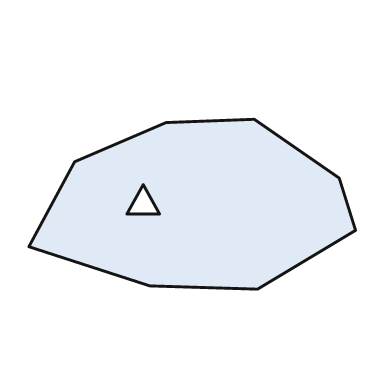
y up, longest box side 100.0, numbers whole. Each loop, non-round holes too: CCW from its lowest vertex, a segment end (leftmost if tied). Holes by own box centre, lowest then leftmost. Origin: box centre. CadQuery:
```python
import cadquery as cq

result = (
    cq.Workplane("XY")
    .moveTo(20.0, -26.0)
    .lineTo(50.0, -8.0)
    .lineTo(45.0, 8.0)
    .lineTo(19.0, 26.0)
    .lineTo(-8.0, 25.0)
    .lineTo(-36.0, 13.0)
    .lineTo(-50.0, -13.0)
    .lineTo(-13.0, -25.0)
    .close()
    .moveTo(-20.0, -3.0)
    .lineTo(-10.0, -3.0)
    .lineTo(-15.0, 6.0)
    .close()
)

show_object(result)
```